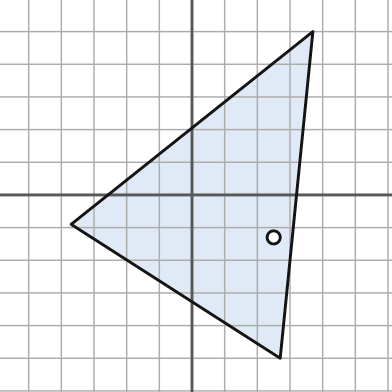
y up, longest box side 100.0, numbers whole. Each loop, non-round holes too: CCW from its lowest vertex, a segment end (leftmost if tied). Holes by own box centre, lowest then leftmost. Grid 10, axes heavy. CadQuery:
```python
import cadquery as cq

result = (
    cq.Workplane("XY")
    .moveTo(27.0, -50.0)
    .lineTo(37.0, 50.0)
    .lineTo(-37.0, -9.0)
    .close()
    .moveTo(25.0, -13.0)
    .circle(2.0)
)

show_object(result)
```